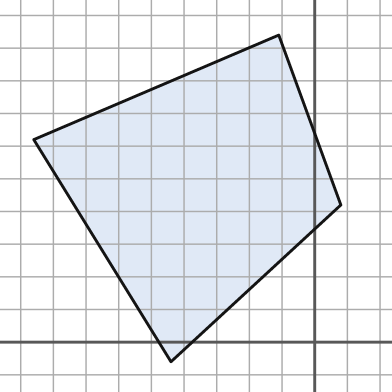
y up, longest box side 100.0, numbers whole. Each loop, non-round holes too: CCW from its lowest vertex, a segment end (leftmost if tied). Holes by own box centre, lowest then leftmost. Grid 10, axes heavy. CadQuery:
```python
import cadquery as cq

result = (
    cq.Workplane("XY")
    .moveTo(-44.0, -6.0)
    .lineTo(8.0, 42.0)
    .lineTo(-11.0, 94.0)
    .lineTo(-86.0, 62.0)
    .close()
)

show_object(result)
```